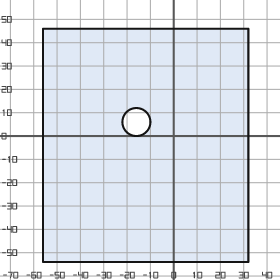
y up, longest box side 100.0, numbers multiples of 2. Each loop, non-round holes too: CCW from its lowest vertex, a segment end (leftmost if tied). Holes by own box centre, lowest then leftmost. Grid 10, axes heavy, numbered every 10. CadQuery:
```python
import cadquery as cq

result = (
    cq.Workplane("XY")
    .moveTo(-56.0, -54.0)
    .lineTo(32.0, -54.0)
    .lineTo(32.0, 46.0)
    .lineTo(-56.0, 46.0)
    .close()
    .moveTo(-16.0, 6.0)
    .circle(6.0)
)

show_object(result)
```